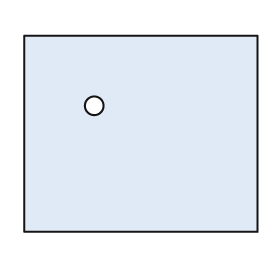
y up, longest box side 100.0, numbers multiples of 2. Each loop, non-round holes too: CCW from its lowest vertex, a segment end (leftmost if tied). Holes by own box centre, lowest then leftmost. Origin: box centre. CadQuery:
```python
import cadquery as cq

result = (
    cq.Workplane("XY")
    .moveTo(-50.0, -42.0)
    .lineTo(50.0, -42.0)
    .lineTo(50.0, 42.0)
    .lineTo(-50.0, 42.0)
    .close()
    .moveTo(-20.0, 12.0)
    .circle(4.0)
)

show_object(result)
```